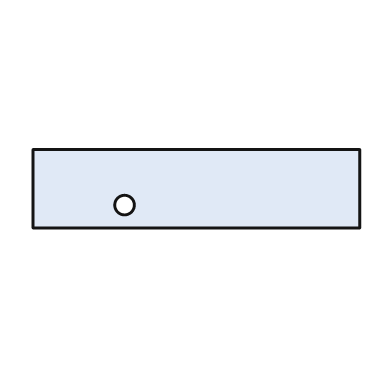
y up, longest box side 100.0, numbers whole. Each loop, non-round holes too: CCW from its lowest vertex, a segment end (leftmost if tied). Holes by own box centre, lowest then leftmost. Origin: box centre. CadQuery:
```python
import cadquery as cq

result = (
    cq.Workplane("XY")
    .moveTo(-50.0, -12.0)
    .lineTo(50.0, -12.0)
    .lineTo(50.0, 12.0)
    .lineTo(-50.0, 12.0)
    .close()
    .moveTo(-22.0, -5.0)
    .circle(3.0)
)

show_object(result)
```